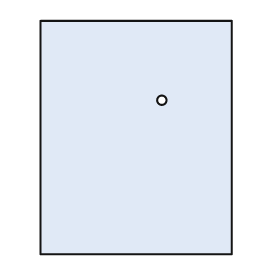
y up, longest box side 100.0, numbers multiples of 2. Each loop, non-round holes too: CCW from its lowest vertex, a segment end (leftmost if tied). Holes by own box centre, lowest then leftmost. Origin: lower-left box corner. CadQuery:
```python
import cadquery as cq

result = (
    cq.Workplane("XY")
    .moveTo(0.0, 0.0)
    .lineTo(82.0, 0.0)
    .lineTo(82.0, 100.0)
    .lineTo(0.0, 100.0)
    .close()
    .moveTo(52.0, 66.0)
    .circle(2.0)
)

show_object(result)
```